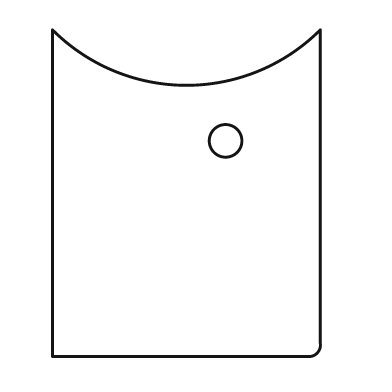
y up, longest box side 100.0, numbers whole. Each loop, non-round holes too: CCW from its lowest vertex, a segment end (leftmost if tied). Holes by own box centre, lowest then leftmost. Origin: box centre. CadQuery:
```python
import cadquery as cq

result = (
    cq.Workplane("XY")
    .moveTo(-41.0, -50.0)
    .lineTo(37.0, -50.0)
    .threePointArc((40.0, -49.0), (41.0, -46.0))
    .lineTo(41.0, 50.0)
    .threePointArc((0.0, 33.0), (-41.0, 50.0))
    .close()
    .moveTo(12.0, 16.0)
    .circle(5.0)
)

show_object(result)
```